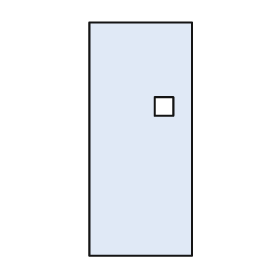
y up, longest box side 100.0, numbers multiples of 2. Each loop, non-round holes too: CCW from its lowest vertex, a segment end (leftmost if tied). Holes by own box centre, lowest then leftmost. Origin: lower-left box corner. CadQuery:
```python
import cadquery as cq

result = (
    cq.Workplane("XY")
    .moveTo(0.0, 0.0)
    .lineTo(44.0, 0.0)
    .lineTo(44.0, 100.0)
    .lineTo(0.0, 100.0)
    .close()
    .moveTo(28.0, 60.0)
    .lineTo(36.0, 60.0)
    .lineTo(36.0, 68.0)
    .lineTo(28.0, 68.0)
    .close()
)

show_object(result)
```